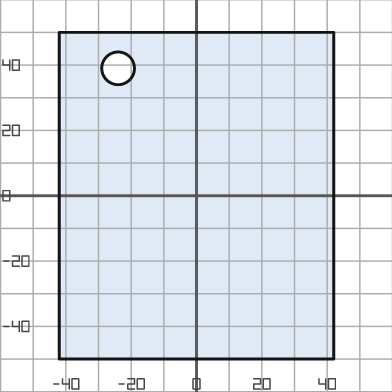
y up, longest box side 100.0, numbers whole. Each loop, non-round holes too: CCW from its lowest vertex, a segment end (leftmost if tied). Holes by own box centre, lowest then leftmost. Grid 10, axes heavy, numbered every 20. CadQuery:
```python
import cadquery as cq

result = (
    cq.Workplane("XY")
    .moveTo(-42.0, -50.0)
    .lineTo(42.0, -50.0)
    .lineTo(42.0, 50.0)
    .lineTo(-42.0, 50.0)
    .close()
    .moveTo(-24.0, 39.0)
    .circle(5.0)
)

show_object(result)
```